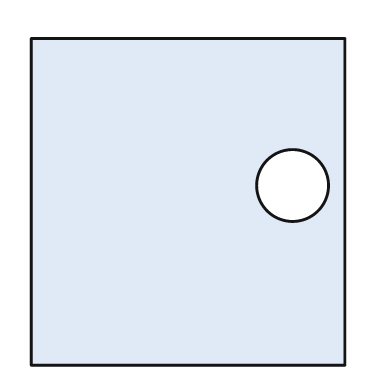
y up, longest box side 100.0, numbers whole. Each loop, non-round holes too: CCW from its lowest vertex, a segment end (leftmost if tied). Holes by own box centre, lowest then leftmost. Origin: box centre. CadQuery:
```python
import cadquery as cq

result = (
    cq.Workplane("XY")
    .moveTo(-48.0, -50.0)
    .lineTo(48.0, -50.0)
    .lineTo(48.0, 50.0)
    .lineTo(-48.0, 50.0)
    .close()
    .moveTo(32.0, 5.0)
    .circle(11.0)
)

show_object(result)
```